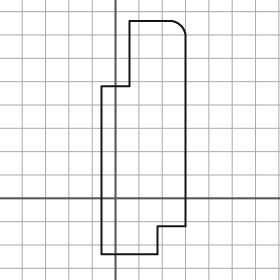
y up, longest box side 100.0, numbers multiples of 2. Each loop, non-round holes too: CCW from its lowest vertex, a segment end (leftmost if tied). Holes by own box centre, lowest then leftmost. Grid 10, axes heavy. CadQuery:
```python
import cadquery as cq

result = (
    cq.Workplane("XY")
    .moveTo(-6.0, -24.0)
    .lineTo(18.0, -24.0)
    .lineTo(18.0, -12.0)
    .lineTo(30.0, -12.0)
    .lineTo(30.0, 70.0)
    .threePointArc((28.0, 74.0), (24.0, 76.0))
    .lineTo(6.0, 76.0)
    .lineTo(6.0, 48.0)
    .lineTo(-6.0, 48.0)
    .close()
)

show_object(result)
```